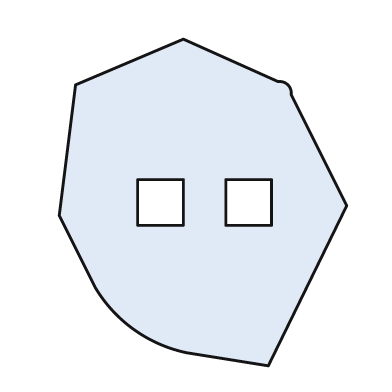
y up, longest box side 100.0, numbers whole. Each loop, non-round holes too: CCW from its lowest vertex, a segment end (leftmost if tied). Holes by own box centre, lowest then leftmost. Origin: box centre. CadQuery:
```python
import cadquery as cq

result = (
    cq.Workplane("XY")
    .moveTo(20.0, -50.0)
    .lineTo(44.0, -1.0)
    .lineTo(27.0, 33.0)
    .threePointArc((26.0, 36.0), (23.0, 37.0))
    .lineTo(-6.0, 50.0)
    .lineTo(-39.0, 36.0)
    .lineTo(-44.0, -4.0)
    .lineTo(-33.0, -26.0)
    .threePointArc((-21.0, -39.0), (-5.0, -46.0))
    .close()
    .moveTo(-20.0, -7.0)
    .lineTo(-6.0, -7.0)
    .lineTo(-6.0, 7.0)
    .lineTo(-20.0, 7.0)
    .close()
    .moveTo(7.0, -7.0)
    .lineTo(21.0, -7.0)
    .lineTo(21.0, 7.0)
    .lineTo(7.0, 7.0)
    .close()
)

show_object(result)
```